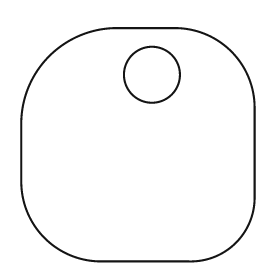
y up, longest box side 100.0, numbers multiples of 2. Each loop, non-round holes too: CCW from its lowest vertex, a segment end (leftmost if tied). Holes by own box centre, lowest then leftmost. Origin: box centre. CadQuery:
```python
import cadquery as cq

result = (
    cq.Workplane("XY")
    .moveTo(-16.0, -50.0)
    .lineTo(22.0, -50.0)
    .threePointArc((42.0, -42.0), (50.0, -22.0))
    .lineTo(50.0, 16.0)
    .threePointArc((40.0, 40.0), (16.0, 50.0))
    .lineTo(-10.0, 50.0)
    .threePointArc((-38.0, 38.0), (-50.0, 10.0))
    .lineTo(-50.0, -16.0)
    .threePointArc((-40.0, -40.0), (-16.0, -50.0))
    .close()
    .moveTo(6.0, 30.0)
    .circle(12.0)
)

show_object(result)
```